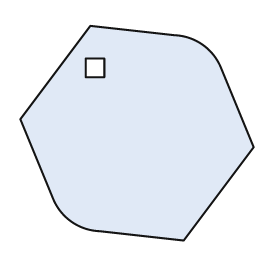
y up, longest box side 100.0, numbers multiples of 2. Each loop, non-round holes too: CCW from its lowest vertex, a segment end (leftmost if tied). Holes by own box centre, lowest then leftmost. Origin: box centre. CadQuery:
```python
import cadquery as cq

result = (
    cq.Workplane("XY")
    .moveTo(20.0, -46.0)
    .lineTo(50.0, -6.0)
    .lineTo(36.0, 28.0)
    .threePointArc((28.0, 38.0), (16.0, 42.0))
    .lineTo(-20.0, 46.0)
    .lineTo(-50.0, 6.0)
    .lineTo(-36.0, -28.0)
    .threePointArc((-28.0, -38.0), (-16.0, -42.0))
    .close()
    .moveTo(-22.0, 24.0)
    .lineTo(-14.0, 24.0)
    .lineTo(-14.0, 32.0)
    .lineTo(-22.0, 32.0)
    .close()
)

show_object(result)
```